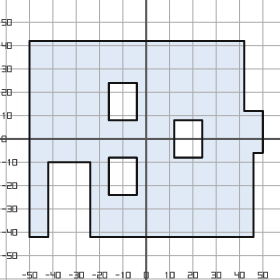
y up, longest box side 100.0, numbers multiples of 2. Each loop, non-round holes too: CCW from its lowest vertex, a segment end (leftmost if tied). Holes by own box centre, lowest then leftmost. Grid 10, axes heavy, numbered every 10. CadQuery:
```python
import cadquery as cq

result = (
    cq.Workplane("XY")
    .moveTo(-50.0, -42.0)
    .lineTo(-42.0, -42.0)
    .lineTo(-42.0, -10.0)
    .lineTo(-24.0, -10.0)
    .lineTo(-24.0, -42.0)
    .lineTo(46.0, -42.0)
    .lineTo(46.0, -6.0)
    .lineTo(50.0, -6.0)
    .lineTo(50.0, 12.0)
    .lineTo(42.0, 12.0)
    .lineTo(42.0, 42.0)
    .lineTo(-50.0, 42.0)
    .close()
    .moveTo(-16.0, -24.0)
    .lineTo(-4.0, -24.0)
    .lineTo(-4.0, -8.0)
    .lineTo(-16.0, -8.0)
    .close()
    .moveTo(12.0, -8.0)
    .lineTo(24.0, -8.0)
    .lineTo(24.0, 8.0)
    .lineTo(12.0, 8.0)
    .close()
    .moveTo(-16.0, 8.0)
    .lineTo(-4.0, 8.0)
    .lineTo(-4.0, 24.0)
    .lineTo(-16.0, 24.0)
    .close()
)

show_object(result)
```